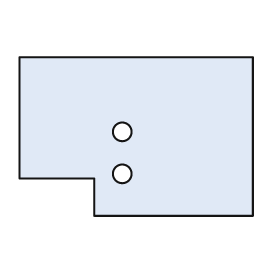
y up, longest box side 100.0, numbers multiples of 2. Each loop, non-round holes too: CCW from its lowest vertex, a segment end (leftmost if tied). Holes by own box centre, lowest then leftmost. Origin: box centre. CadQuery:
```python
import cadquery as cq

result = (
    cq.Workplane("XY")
    .moveTo(-18.0, -34.0)
    .lineTo(50.0, -34.0)
    .lineTo(50.0, 34.0)
    .lineTo(-50.0, 34.0)
    .lineTo(-50.0, -18.0)
    .lineTo(-18.0, -18.0)
    .close()
    .moveTo(-6.0, -16.0)
    .circle(4.0)
    .moveTo(-6.0, 2.0)
    .circle(4.0)
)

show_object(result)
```